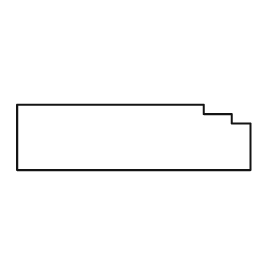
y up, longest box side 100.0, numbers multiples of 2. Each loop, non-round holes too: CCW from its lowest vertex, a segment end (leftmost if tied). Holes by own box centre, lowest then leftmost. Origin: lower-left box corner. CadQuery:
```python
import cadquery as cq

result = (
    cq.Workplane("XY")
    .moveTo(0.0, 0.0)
    .lineTo(100.0, 0.0)
    .lineTo(100.0, 20.0)
    .lineTo(92.0, 20.0)
    .lineTo(92.0, 24.0)
    .lineTo(80.0, 24.0)
    .lineTo(80.0, 28.0)
    .lineTo(0.0, 28.0)
    .close()
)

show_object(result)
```